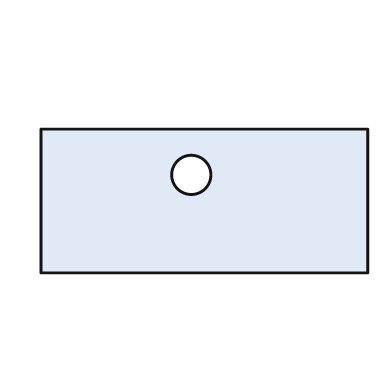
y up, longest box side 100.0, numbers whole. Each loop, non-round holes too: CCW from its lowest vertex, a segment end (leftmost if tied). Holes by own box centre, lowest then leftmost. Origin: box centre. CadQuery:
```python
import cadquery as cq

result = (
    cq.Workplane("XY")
    .moveTo(-50.0, -22.0)
    .lineTo(50.0, -22.0)
    .lineTo(50.0, 22.0)
    .lineTo(-50.0, 22.0)
    .close()
    .moveTo(-4.0, 8.0)
    .circle(6.0)
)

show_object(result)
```